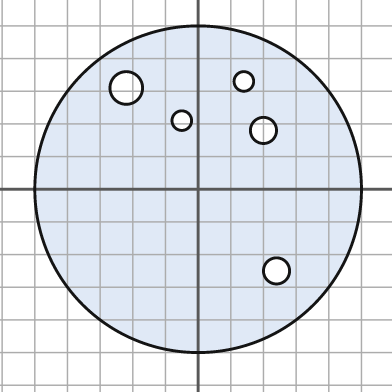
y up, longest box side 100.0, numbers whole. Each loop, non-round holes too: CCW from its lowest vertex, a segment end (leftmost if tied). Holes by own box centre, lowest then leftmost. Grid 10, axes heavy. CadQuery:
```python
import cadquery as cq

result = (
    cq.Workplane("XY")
    .moveTo(0.0, 0.0)
    .circle(50.0)
    .moveTo(24.0, -25.0)
    .circle(4.0)
    .moveTo(20.0, 18.0)
    .circle(4.0)
    .moveTo(-5.0, 21.0)
    .circle(3.0)
    .moveTo(-22.0, 31.0)
    .circle(5.0)
    .moveTo(14.0, 33.0)
    .circle(3.0)
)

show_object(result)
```